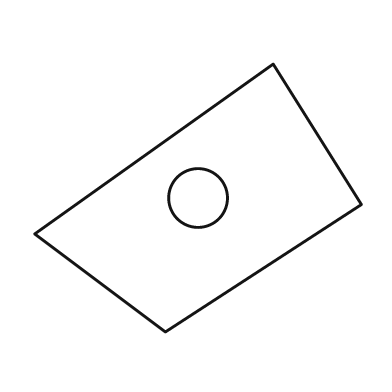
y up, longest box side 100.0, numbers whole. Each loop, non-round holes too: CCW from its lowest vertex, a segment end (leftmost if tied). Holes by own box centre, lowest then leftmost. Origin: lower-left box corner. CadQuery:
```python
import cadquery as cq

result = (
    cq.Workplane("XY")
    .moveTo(40.0, 0.0)
    .lineTo(100.0, 39.0)
    .lineTo(73.0, 82.0)
    .lineTo(0.0, 30.0)
    .close()
    .moveTo(50.0, 41.0)
    .circle(9.0)
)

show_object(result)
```